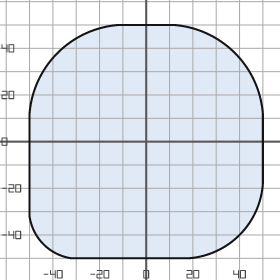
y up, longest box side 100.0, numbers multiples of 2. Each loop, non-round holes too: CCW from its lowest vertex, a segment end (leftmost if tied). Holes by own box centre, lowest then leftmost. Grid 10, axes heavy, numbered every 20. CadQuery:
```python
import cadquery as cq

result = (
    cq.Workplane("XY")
    .moveTo(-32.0, -50.0)
    .lineTo(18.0, -50.0)
    .threePointArc((40.0, -40.0), (50.0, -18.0))
    .lineTo(50.0, 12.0)
    .threePointArc((38.0, 38.0), (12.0, 50.0))
    .lineTo(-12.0, 50.0)
    .threePointArc((-38.0, 38.0), (-50.0, 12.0))
    .lineTo(-50.0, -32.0)
    .threePointArc((-44.0, -44.0), (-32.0, -50.0))
    .close()
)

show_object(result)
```